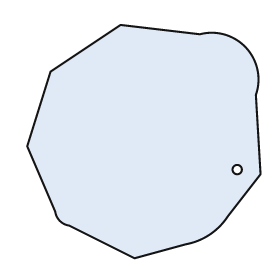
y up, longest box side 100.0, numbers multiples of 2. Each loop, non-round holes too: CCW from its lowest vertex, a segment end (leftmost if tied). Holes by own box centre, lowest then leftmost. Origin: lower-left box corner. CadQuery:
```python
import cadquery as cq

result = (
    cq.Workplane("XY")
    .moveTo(46.0, 0.0)
    .lineTo(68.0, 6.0)
    .threePointArc((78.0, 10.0), (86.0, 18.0))
    .lineTo(100.0, 36.0)
    .lineTo(98.0, 70.0)
    .threePointArc((94.0, 90.0), (74.0, 96.0))
    .lineTo(40.0, 100.0)
    .lineTo(10.0, 80.0)
    .lineTo(0.0, 48.0)
    .lineTo(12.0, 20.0)
    .threePointArc((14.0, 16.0), (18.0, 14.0))
    .close()
    .moveTo(90.0, 38.0)
    .circle(2.0)
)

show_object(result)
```